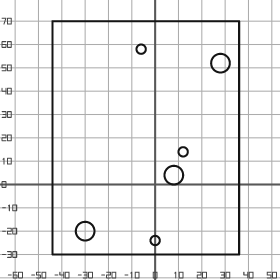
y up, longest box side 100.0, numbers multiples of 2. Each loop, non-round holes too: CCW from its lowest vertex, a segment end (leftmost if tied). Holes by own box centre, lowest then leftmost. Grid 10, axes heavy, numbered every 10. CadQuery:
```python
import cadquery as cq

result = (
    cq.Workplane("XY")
    .moveTo(-44.0, -30.0)
    .lineTo(36.0, -30.0)
    .lineTo(36.0, 70.0)
    .lineTo(-44.0, 70.0)
    .close()
    .moveTo(0.0, -24.0)
    .circle(2.0)
    .moveTo(-30.0, -20.0)
    .circle(4.0)
    .moveTo(8.0, 4.0)
    .circle(4.0)
    .moveTo(12.0, 14.0)
    .circle(2.0)
    .moveTo(28.0, 52.0)
    .circle(4.0)
    .moveTo(-6.0, 58.0)
    .circle(2.0)
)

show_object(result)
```